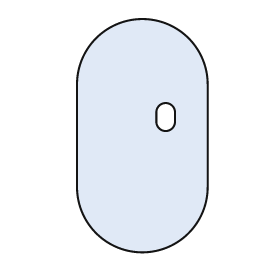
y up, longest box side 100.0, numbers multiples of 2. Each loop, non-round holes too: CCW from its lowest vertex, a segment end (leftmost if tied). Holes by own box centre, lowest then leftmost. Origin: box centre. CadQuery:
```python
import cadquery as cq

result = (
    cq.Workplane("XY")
    .moveTo(-28.0, -22.0)
    .threePointArc((0.0, -50.0), (28.0, -22.0))
    .lineTo(28.0, 22.0)
    .threePointArc((0.0, 50.0), (-28.0, 22.0))
    .close()
    .moveTo(6.0, 6.0)
    .threePointArc((10.0, 2.0), (14.0, 6.0))
    .lineTo(14.0, 10.0)
    .threePointArc((10.0, 14.0), (6.0, 10.0))
    .close()
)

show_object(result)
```